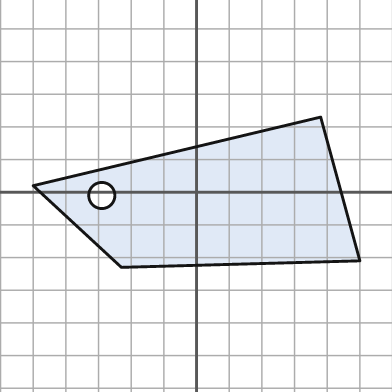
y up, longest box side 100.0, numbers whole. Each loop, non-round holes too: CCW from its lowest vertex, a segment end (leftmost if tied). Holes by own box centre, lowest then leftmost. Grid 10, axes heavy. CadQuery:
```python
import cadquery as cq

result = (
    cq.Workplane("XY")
    .moveTo(-23.0, -23.0)
    .lineTo(50.0, -21.0)
    .lineTo(38.0, 23.0)
    .lineTo(-50.0, 2.0)
    .close()
    .moveTo(-29.0, -1.0)
    .circle(4.0)
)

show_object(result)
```